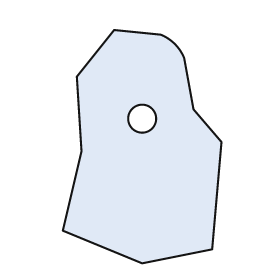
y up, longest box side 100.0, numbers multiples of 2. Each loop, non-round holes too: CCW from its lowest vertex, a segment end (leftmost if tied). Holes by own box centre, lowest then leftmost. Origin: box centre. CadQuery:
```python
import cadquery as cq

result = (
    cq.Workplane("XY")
    .moveTo(0.0, -50.0)
    .lineTo(30.0, -44.0)
    .lineTo(34.0, 2.0)
    .lineTo(22.0, 16.0)
    .lineTo(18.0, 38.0)
    .threePointArc((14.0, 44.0), (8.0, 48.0))
    .lineTo(-12.0, 50.0)
    .lineTo(-28.0, 30.0)
    .lineTo(-26.0, -2.0)
    .lineTo(-34.0, -36.0)
    .close()
    .moveTo(0.0, 12.0)
    .circle(6.0)
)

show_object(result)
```